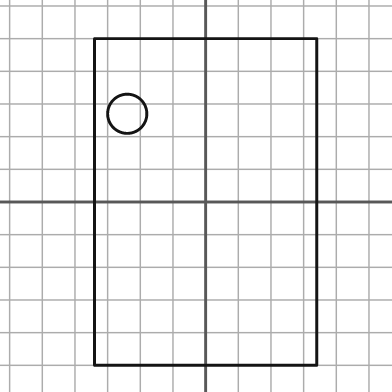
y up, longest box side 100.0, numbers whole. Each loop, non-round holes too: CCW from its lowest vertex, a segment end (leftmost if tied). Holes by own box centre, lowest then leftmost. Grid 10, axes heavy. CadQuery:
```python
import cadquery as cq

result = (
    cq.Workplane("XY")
    .moveTo(-34.0, -50.0)
    .lineTo(34.0, -50.0)
    .lineTo(34.0, 50.0)
    .lineTo(-34.0, 50.0)
    .close()
    .moveTo(-24.0, 27.0)
    .circle(6.0)
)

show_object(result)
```